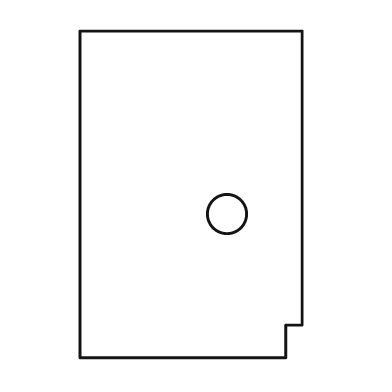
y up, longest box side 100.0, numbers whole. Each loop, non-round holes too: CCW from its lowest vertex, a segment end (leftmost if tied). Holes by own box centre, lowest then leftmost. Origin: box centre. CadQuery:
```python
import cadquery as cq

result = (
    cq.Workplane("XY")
    .moveTo(-34.0, -50.0)
    .lineTo(29.0, -50.0)
    .lineTo(29.0, -40.0)
    .lineTo(34.0, -40.0)
    .lineTo(34.0, 50.0)
    .lineTo(-34.0, 50.0)
    .close()
    .moveTo(11.0, -6.0)
    .circle(6.0)
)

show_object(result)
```